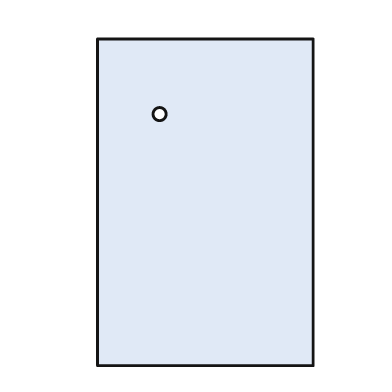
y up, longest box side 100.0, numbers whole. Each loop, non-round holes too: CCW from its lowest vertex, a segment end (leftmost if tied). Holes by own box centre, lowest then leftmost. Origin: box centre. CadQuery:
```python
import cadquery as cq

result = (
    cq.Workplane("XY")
    .moveTo(-33.0, -50.0)
    .lineTo(33.0, -50.0)
    .lineTo(33.0, 50.0)
    .lineTo(-33.0, 50.0)
    .close()
    .moveTo(-14.0, 27.0)
    .circle(2.0)
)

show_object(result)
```